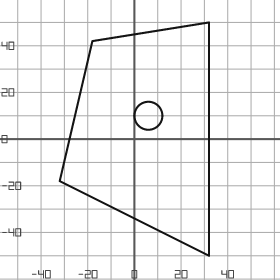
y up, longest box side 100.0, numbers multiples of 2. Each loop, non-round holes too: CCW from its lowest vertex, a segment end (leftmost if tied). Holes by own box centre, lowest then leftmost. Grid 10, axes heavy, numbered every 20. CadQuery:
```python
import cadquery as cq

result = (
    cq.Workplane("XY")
    .moveTo(32.0, -50.0)
    .lineTo(32.0, 50.0)
    .lineTo(-18.0, 42.0)
    .lineTo(-32.0, -18.0)
    .close()
    .moveTo(6.0, 10.0)
    .circle(6.0)
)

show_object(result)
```